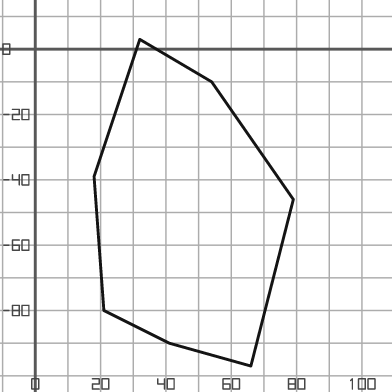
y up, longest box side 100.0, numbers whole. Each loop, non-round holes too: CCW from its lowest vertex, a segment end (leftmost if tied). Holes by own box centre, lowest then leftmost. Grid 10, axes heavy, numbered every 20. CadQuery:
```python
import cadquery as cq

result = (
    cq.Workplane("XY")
    .moveTo(66.0, -97.0)
    .lineTo(79.0, -46.0)
    .lineTo(54.0, -10.0)
    .lineTo(32.0, 3.0)
    .lineTo(18.0, -39.0)
    .lineTo(21.0, -80.0)
    .lineTo(41.0, -90.0)
    .close()
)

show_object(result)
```